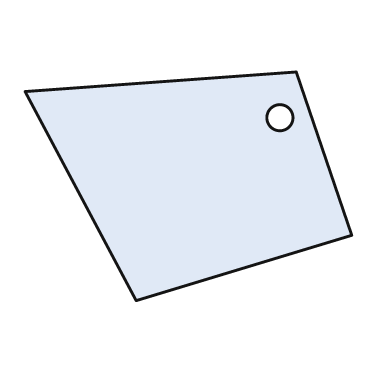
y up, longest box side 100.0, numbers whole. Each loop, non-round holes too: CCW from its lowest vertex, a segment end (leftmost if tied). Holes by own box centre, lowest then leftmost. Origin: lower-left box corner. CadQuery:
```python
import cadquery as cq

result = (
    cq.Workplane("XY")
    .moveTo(34.0, 0.0)
    .lineTo(100.0, 20.0)
    .lineTo(83.0, 70.0)
    .lineTo(0.0, 64.0)
    .close()
    .moveTo(78.0, 56.0)
    .circle(4.0)
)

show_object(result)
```